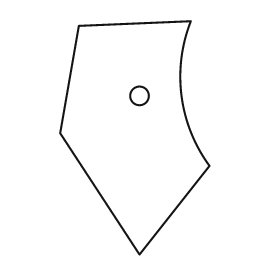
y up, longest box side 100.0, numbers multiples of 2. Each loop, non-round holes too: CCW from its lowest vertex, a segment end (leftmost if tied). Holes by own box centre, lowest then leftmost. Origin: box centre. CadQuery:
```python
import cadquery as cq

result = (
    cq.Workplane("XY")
    .moveTo(2.0, -50.0)
    .lineTo(32.0, -12.0)
    .threePointArc((20.0, 18.0), (24.0, 50.0))
    .lineTo(-24.0, 48.0)
    .lineTo(-32.0, 2.0)
    .close()
    .moveTo(2.0, 18.0)
    .circle(4.0)
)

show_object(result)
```